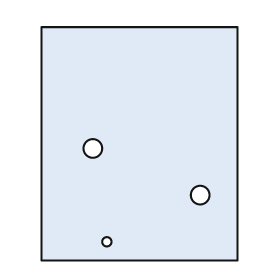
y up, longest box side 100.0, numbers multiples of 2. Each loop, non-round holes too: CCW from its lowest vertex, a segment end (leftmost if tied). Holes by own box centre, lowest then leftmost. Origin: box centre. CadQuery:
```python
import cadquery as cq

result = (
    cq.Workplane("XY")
    .moveTo(-42.0, -50.0)
    .lineTo(42.0, -50.0)
    .lineTo(42.0, 50.0)
    .lineTo(-42.0, 50.0)
    .close()
    .moveTo(-14.0, -42.0)
    .circle(2.0)
    .moveTo(26.0, -22.0)
    .circle(4.0)
    .moveTo(-20.0, -2.0)
    .circle(4.0)
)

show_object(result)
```